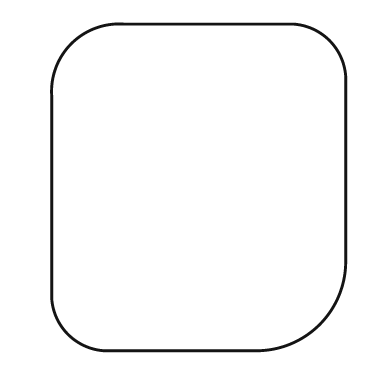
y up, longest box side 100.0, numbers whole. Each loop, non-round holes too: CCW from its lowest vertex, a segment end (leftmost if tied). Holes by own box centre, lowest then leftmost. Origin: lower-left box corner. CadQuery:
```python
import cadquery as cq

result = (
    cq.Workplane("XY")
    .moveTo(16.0, 0.0)
    .lineTo(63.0, 0.0)
    .threePointArc((82.0, 8.0), (90.0, 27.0))
    .lineTo(90.0, 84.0)
    .threePointArc((85.0, 95.0), (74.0, 100.0))
    .lineTo(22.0, 100.0)
    .threePointArc((6.0, 94.0), (0.0, 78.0))
    .lineTo(0.0, 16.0)
    .threePointArc((5.0, 5.0), (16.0, 0.0))
    .close()
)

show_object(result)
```